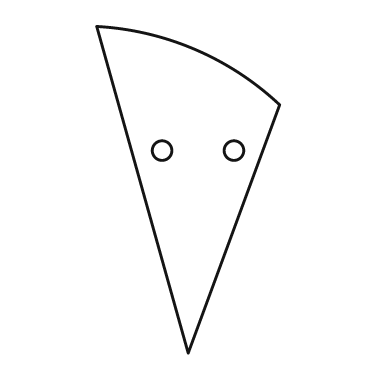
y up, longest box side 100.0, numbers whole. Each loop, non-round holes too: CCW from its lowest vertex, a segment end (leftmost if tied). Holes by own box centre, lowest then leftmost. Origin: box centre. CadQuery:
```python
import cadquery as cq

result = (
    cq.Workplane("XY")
    .moveTo(0.0, -50.0)
    .lineTo(28.0, 26.0)
    .threePointArc((2.0, 43.0), (-28.0, 50.0))
    .close()
    .moveTo(-8.0, 12.0)
    .circle(3.0)
    .moveTo(14.0, 12.0)
    .circle(3.0)
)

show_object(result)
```